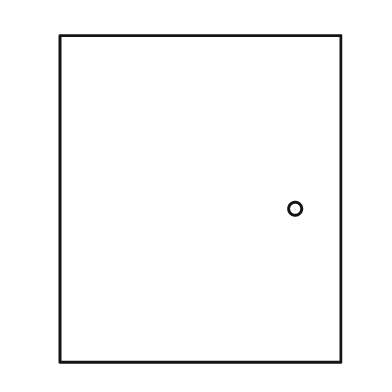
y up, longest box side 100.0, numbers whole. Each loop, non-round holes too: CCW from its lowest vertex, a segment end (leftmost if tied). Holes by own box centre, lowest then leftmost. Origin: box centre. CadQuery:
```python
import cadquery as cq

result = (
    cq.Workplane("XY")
    .moveTo(-43.0, -50.0)
    .lineTo(43.0, -50.0)
    .lineTo(43.0, 50.0)
    .lineTo(-43.0, 50.0)
    .close()
    .moveTo(29.0, -3.0)
    .circle(2.0)
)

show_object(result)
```